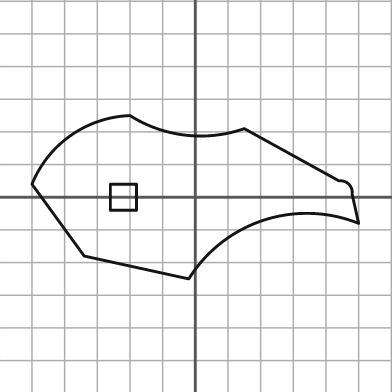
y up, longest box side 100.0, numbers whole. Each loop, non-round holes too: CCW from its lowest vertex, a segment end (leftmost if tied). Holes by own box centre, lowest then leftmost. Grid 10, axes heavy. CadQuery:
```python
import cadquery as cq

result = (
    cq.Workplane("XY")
    .moveTo(-2.0, -25.0)
    .threePointArc((21.0, -7.0), (50.0, -8.0))
    .lineTo(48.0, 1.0)
    .threePointArc((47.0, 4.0), (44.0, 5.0))
    .lineTo(15.0, 21.0)
    .threePointArc((-3.0, 19.0), (-20.0, 25.0))
    .threePointArc((-38.0, 19.0), (-50.0, 4.0))
    .lineTo(-34.0, -18.0)
    .close()
    .moveTo(-26.0, -4.0)
    .lineTo(-18.0, -4.0)
    .lineTo(-18.0, 4.0)
    .lineTo(-26.0, 4.0)
    .close()
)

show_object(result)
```